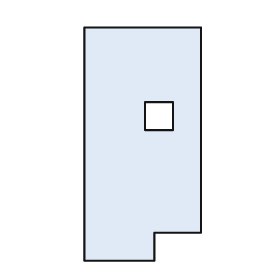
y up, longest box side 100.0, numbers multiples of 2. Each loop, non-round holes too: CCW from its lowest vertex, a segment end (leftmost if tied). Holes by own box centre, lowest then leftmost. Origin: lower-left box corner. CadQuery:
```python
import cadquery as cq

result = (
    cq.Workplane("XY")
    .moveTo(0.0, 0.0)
    .lineTo(30.0, 0.0)
    .lineTo(30.0, 12.0)
    .lineTo(50.0, 12.0)
    .lineTo(50.0, 100.0)
    .lineTo(0.0, 100.0)
    .close()
    .moveTo(26.0, 56.0)
    .lineTo(38.0, 56.0)
    .lineTo(38.0, 68.0)
    .lineTo(26.0, 68.0)
    .close()
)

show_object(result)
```